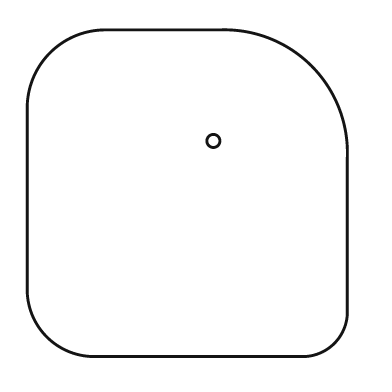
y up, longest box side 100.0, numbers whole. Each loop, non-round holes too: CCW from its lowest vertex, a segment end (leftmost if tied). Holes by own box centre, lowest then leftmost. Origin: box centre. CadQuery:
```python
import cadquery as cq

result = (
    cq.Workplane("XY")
    .moveTo(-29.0, -50.0)
    .lineTo(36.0, -50.0)
    .threePointArc((45.0, -46.0), (49.0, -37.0))
    .lineTo(49.0, 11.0)
    .threePointArc((38.0, 39.0), (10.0, 50.0))
    .lineTo(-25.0, 50.0)
    .threePointArc((-42.0, 43.0), (-49.0, 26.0))
    .lineTo(-49.0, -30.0)
    .threePointArc((-43.0, -44.0), (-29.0, -50.0))
    .close()
    .moveTo(8.0, 16.0)
    .circle(2.0)
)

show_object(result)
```